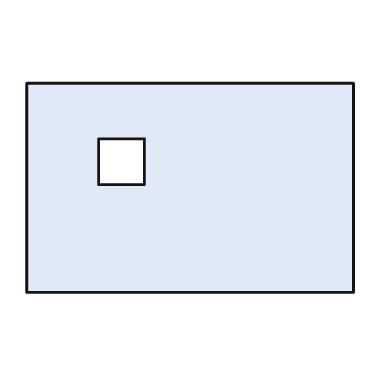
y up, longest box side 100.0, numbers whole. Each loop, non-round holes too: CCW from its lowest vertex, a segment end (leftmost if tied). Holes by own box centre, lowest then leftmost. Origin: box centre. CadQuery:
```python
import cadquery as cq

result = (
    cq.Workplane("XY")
    .moveTo(-50.0, -32.0)
    .lineTo(50.0, -32.0)
    .lineTo(50.0, 32.0)
    .lineTo(-50.0, 32.0)
    .close()
    .moveTo(-28.0, 1.0)
    .lineTo(-14.0, 1.0)
    .lineTo(-14.0, 15.0)
    .lineTo(-28.0, 15.0)
    .close()
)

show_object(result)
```